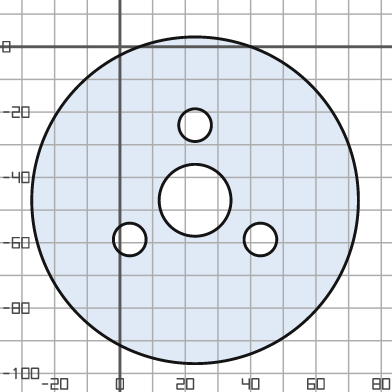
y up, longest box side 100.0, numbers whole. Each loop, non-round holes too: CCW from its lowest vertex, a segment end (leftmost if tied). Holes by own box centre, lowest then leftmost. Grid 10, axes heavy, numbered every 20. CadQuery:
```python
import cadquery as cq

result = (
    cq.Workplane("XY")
    .moveTo(23.0, -47.0)
    .circle(50.0)
    .moveTo(3.0, -59.0)
    .circle(5.0)
    .moveTo(43.0, -59.0)
    .circle(5.0)
    .moveTo(23.0, -47.0)
    .circle(11.0)
    .moveTo(23.0, -24.0)
    .circle(5.0)
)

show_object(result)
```